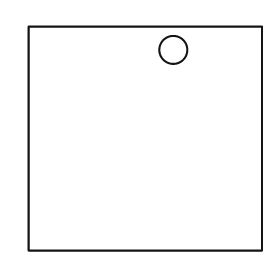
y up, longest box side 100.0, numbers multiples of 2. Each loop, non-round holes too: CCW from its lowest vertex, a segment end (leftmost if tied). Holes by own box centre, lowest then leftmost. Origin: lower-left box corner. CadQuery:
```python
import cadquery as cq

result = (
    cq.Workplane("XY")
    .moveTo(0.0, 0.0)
    .lineTo(100.0, 0.0)
    .lineTo(100.0, 96.0)
    .lineTo(0.0, 96.0)
    .close()
    .moveTo(62.0, 86.0)
    .circle(6.0)
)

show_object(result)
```